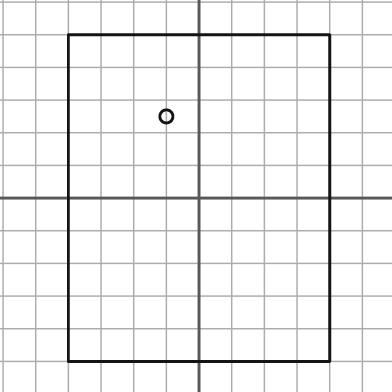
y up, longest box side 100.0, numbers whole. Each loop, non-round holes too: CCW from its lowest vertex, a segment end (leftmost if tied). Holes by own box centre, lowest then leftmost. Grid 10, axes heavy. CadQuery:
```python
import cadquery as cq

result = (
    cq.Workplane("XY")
    .moveTo(-40.0, -50.0)
    .lineTo(40.0, -50.0)
    .lineTo(40.0, 50.0)
    .lineTo(-40.0, 50.0)
    .close()
    .moveTo(-10.0, 25.0)
    .circle(2.0)
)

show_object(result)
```